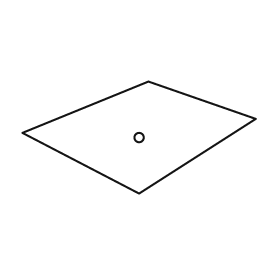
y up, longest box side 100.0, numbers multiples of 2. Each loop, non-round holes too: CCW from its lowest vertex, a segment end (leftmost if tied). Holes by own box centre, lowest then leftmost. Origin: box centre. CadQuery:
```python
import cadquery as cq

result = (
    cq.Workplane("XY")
    .moveTo(0.0, -24.0)
    .lineTo(50.0, 8.0)
    .lineTo(4.0, 24.0)
    .lineTo(-50.0, 2.0)
    .close()
    .moveTo(0.0, 0.0)
    .circle(2.0)
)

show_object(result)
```